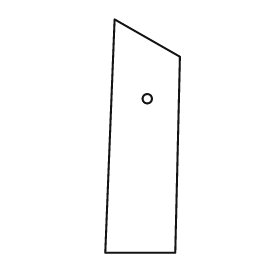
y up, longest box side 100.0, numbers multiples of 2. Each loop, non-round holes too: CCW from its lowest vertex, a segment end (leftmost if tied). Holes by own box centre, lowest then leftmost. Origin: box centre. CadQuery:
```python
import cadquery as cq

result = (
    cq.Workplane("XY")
    .moveTo(-16.0, -50.0)
    .lineTo(14.0, -50.0)
    .lineTo(16.0, 34.0)
    .lineTo(-12.0, 50.0)
    .close()
    .moveTo(2.0, 16.0)
    .circle(2.0)
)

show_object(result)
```